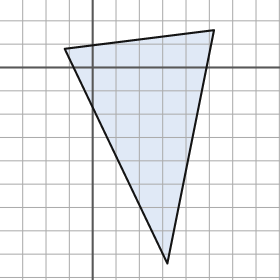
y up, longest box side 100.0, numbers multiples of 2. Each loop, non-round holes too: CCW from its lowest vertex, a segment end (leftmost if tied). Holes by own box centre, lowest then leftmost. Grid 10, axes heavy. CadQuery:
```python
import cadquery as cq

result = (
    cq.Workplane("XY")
    .moveTo(32.0, -84.0)
    .lineTo(52.0, 16.0)
    .lineTo(-12.0, 8.0)
    .close()
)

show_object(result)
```